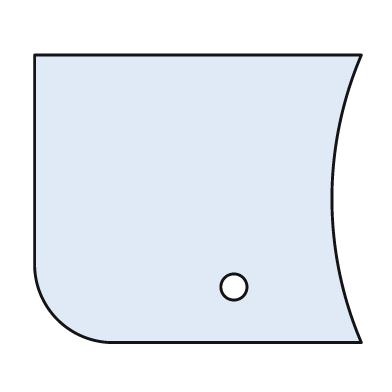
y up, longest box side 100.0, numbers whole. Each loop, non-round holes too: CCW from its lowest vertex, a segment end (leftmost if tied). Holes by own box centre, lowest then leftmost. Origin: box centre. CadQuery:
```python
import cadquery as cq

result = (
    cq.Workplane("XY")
    .moveTo(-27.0, -44.0)
    .lineTo(50.0, -44.0)
    .threePointArc((41.0, 0.0), (50.0, 44.0))
    .lineTo(-50.0, 44.0)
    .lineTo(-50.0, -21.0)
    .threePointArc((-43.0, -37.0), (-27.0, -44.0))
    .close()
    .moveTo(11.0, -27.0)
    .circle(4.0)
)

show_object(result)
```